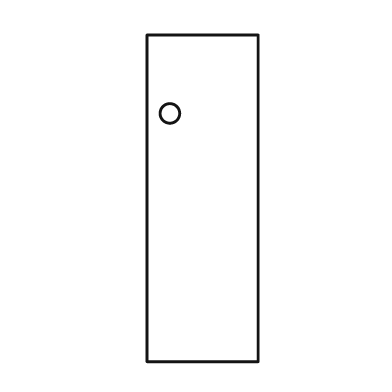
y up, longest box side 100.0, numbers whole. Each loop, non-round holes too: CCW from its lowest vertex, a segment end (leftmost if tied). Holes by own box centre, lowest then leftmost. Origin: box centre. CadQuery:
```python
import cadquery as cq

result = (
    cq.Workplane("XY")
    .moveTo(-17.0, -50.0)
    .lineTo(17.0, -50.0)
    .lineTo(17.0, 50.0)
    .lineTo(-17.0, 50.0)
    .close()
    .moveTo(-10.0, 26.0)
    .circle(3.0)
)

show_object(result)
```